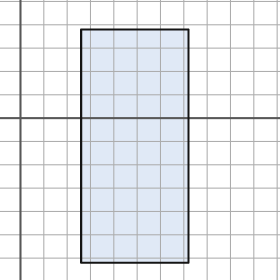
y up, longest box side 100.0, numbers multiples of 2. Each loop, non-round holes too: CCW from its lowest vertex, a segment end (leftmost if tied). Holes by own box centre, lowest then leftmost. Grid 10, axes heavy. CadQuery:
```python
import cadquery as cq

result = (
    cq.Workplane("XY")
    .moveTo(26.0, -62.0)
    .lineTo(72.0, -62.0)
    .lineTo(72.0, 38.0)
    .lineTo(26.0, 38.0)
    .close()
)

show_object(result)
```